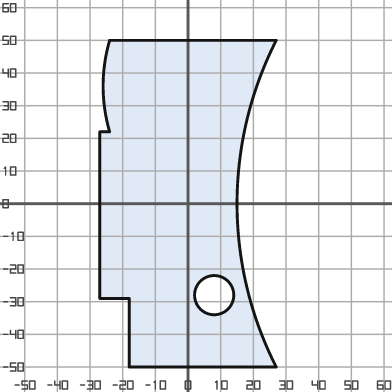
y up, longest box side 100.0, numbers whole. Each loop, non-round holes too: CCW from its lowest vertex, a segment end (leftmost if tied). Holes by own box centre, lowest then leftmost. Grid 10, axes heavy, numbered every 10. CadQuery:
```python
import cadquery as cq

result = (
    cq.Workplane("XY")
    .moveTo(-18.0, -50.0)
    .lineTo(27.0, -50.0)
    .threePointArc((15.0, 0.0), (27.0, 50.0))
    .lineTo(-24.0, 50.0)
    .threePointArc((-26.0, 36.0), (-24.0, 22.0))
    .lineTo(-27.0, 22.0)
    .lineTo(-27.0, -29.0)
    .lineTo(-18.0, -29.0)
    .close()
    .moveTo(8.0, -28.0)
    .circle(6.0)
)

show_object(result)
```